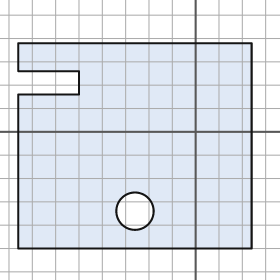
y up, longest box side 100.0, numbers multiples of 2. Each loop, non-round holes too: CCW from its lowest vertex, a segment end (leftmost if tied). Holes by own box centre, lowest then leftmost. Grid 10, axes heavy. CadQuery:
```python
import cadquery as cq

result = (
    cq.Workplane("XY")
    .moveTo(-76.0, -50.0)
    .lineTo(24.0, -50.0)
    .lineTo(24.0, 38.0)
    .lineTo(-76.0, 38.0)
    .lineTo(-76.0, 26.0)
    .lineTo(-50.0, 26.0)
    .lineTo(-50.0, 16.0)
    .lineTo(-76.0, 16.0)
    .close()
    .moveTo(-26.0, -34.0)
    .circle(8.0)
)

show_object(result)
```